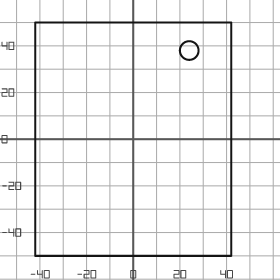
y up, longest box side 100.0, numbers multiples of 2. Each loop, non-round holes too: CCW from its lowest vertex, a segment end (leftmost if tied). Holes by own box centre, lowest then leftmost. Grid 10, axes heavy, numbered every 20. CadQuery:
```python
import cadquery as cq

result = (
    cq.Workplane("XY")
    .moveTo(-42.0, -50.0)
    .lineTo(42.0, -50.0)
    .lineTo(42.0, 50.0)
    .lineTo(-42.0, 50.0)
    .close()
    .moveTo(24.0, 38.0)
    .circle(4.0)
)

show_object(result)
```